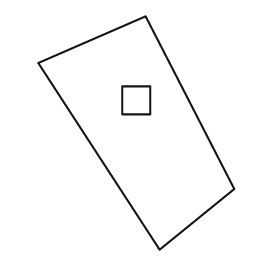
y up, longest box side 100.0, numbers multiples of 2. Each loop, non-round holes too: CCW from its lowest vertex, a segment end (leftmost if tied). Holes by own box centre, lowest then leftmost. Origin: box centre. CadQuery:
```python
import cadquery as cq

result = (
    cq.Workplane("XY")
    .moveTo(10.0, -50.0)
    .lineTo(42.0, -24.0)
    .lineTo(4.0, 50.0)
    .lineTo(-42.0, 30.0)
    .close()
    .moveTo(-6.0, 8.0)
    .lineTo(6.0, 8.0)
    .lineTo(6.0, 20.0)
    .lineTo(-6.0, 20.0)
    .close()
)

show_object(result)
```